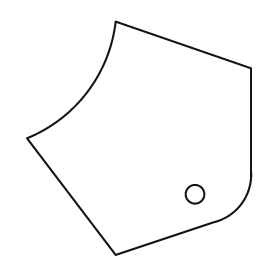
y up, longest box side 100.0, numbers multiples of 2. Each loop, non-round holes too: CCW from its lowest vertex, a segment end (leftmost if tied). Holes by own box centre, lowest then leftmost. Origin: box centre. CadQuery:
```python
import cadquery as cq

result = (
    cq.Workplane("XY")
    .moveTo(-10.0, -50.0)
    .lineTo(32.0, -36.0)
    .threePointArc((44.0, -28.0), (48.0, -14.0))
    .lineTo(48.0, 30.0)
    .lineTo(-10.0, 50.0)
    .threePointArc((-22.0, 20.0), (-48.0, 0.0))
    .close()
    .moveTo(24.0, -24.0)
    .circle(4.0)
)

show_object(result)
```